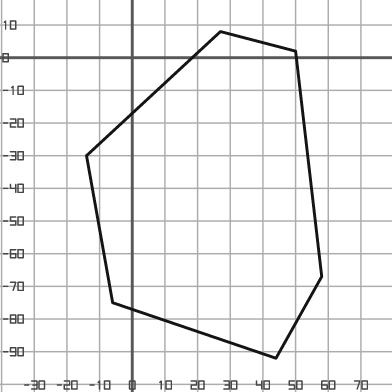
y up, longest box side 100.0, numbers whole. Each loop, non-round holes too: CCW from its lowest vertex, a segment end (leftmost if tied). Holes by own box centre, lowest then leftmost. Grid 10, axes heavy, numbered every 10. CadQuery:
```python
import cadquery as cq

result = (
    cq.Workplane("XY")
    .moveTo(44.0, -92.0)
    .lineTo(58.0, -67.0)
    .lineTo(50.0, 2.0)
    .lineTo(27.0, 8.0)
    .lineTo(-14.0, -30.0)
    .lineTo(-6.0, -75.0)
    .close()
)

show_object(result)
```